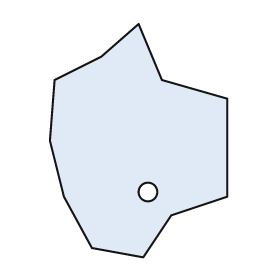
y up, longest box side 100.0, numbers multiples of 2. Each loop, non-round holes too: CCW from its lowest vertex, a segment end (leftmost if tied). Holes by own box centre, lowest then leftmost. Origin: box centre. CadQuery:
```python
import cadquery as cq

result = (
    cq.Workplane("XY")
    .moveTo(2.0, -50.0)
    .lineTo(14.0, -32.0)
    .lineTo(38.0, -24.0)
    .lineTo(38.0, 18.0)
    .lineTo(10.0, 26.0)
    .lineTo(0.0, 50.0)
    .lineTo(-16.0, 36.0)
    .lineTo(-36.0, 26.0)
    .lineTo(-38.0, 0.0)
    .lineTo(-32.0, -24.0)
    .lineTo(-20.0, -46.0)
    .close()
    .moveTo(4.0, -22.0)
    .circle(4.0)
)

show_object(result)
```